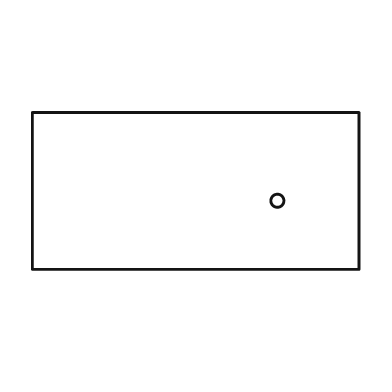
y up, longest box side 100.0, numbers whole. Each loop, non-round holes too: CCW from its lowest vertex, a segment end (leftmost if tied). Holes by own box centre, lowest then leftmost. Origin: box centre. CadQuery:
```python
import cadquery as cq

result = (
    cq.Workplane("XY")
    .moveTo(-50.0, -24.0)
    .lineTo(50.0, -24.0)
    .lineTo(50.0, 24.0)
    .lineTo(-50.0, 24.0)
    .close()
    .moveTo(25.0, -3.0)
    .circle(2.0)
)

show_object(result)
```